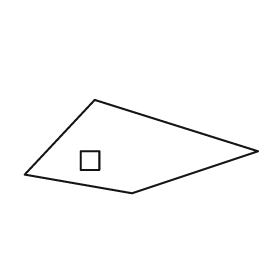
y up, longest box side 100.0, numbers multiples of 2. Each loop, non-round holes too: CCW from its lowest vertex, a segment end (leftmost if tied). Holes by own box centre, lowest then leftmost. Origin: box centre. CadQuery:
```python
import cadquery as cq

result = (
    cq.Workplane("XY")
    .moveTo(-4.0, -20.0)
    .lineTo(50.0, -2.0)
    .lineTo(-20.0, 20.0)
    .lineTo(-50.0, -12.0)
    .close()
    .moveTo(-26.0, -10.0)
    .lineTo(-18.0, -10.0)
    .lineTo(-18.0, -2.0)
    .lineTo(-26.0, -2.0)
    .close()
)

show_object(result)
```